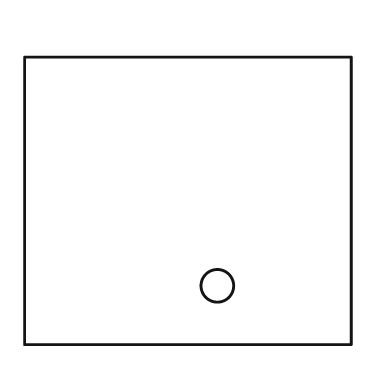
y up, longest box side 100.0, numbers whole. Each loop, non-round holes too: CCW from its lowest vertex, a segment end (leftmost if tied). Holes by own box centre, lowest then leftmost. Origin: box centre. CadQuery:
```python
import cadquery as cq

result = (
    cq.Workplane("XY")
    .moveTo(-50.0, -44.0)
    .lineTo(50.0, -44.0)
    .lineTo(50.0, 44.0)
    .lineTo(-50.0, 44.0)
    .close()
    .moveTo(9.0, -26.0)
    .circle(5.0)
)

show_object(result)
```